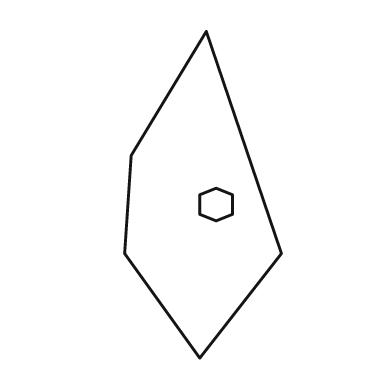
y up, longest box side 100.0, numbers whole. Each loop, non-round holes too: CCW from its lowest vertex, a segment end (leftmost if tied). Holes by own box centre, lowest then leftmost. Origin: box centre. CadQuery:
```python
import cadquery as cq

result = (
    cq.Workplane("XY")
    .moveTo(-1.0, -50.0)
    .lineTo(24.0, -18.0)
    .lineTo(1.0, 50.0)
    .lineTo(-22.0, 12.0)
    .lineTo(-24.0, -18.0)
    .close()
    .moveTo(4.0, -8.0)
    .lineTo(9.0, -6.0)
    .lineTo(9.0, 0.0)
    .lineTo(4.0, 2.0)
    .lineTo(-1.0, 0.0)
    .lineTo(-1.0, -6.0)
    .close()
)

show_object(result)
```